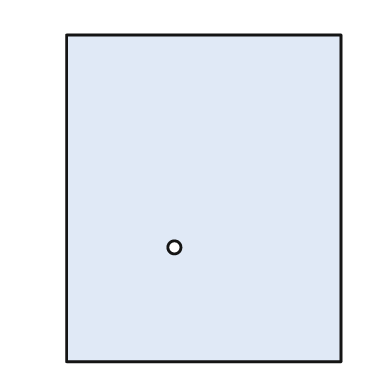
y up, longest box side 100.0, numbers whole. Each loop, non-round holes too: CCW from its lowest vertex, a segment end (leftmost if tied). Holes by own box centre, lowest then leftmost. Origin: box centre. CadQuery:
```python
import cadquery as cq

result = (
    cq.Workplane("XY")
    .moveTo(-42.0, -50.0)
    .lineTo(42.0, -50.0)
    .lineTo(42.0, 50.0)
    .lineTo(-42.0, 50.0)
    .close()
    .moveTo(-9.0, -15.0)
    .circle(2.0)
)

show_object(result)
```